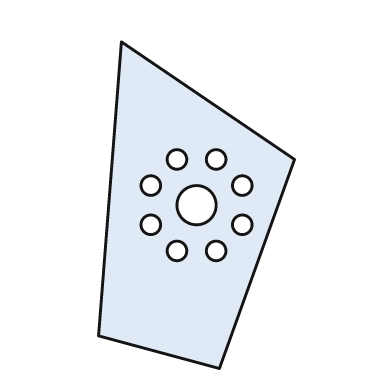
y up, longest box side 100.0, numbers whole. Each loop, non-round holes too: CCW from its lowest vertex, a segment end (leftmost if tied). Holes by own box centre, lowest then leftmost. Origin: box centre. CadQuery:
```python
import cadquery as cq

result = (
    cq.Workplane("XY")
    .moveTo(7.0, -50.0)
    .lineTo(30.0, 14.0)
    .lineTo(-23.0, 50.0)
    .lineTo(-30.0, -40.0)
    .close()
    .moveTo(-6.0, -14.0)
    .circle(3.0)
    .moveTo(6.0, -14.0)
    .circle(3.0)
    .moveTo(-14.0, -6.0)
    .circle(3.0)
    .moveTo(14.0, -6.0)
    .circle(3.0)
    .moveTo(0.0, 0.0)
    .circle(6.0)
    .moveTo(-14.0, 6.0)
    .circle(3.0)
    .moveTo(14.0, 6.0)
    .circle(3.0)
    .moveTo(-6.0, 14.0)
    .circle(3.0)
    .moveTo(6.0, 14.0)
    .circle(3.0)
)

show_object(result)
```